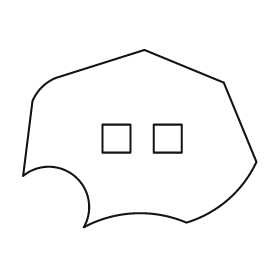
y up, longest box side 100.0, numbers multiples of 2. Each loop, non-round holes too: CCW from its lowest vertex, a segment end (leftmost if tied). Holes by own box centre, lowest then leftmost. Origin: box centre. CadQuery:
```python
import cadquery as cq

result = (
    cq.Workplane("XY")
    .moveTo(-24.0, -38.0)
    .threePointArc((-2.0, -32.0), (20.0, -36.0))
    .threePointArc((38.0, -26.0), (50.0, -10.0))
    .lineTo(36.0, 24.0)
    .lineTo(2.0, 38.0)
    .lineTo(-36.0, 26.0)
    .threePointArc((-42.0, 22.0), (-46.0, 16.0))
    .lineTo(-50.0, -16.0)
    .threePointArc((-28.0, -16.0), (-24.0, -38.0))
    .close()
    .moveTo(-16.0, -6.0)
    .lineTo(-4.0, -6.0)
    .lineTo(-4.0, 6.0)
    .lineTo(-16.0, 6.0)
    .close()
    .moveTo(6.0, -6.0)
    .lineTo(18.0, -6.0)
    .lineTo(18.0, 6.0)
    .lineTo(6.0, 6.0)
    .close()
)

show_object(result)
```